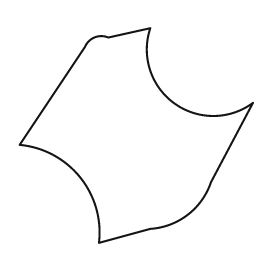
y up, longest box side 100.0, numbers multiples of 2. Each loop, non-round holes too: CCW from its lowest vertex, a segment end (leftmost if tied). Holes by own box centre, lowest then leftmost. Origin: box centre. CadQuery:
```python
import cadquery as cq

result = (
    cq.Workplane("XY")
    .moveTo(-16.0, -46.0)
    .lineTo(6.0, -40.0)
    .threePointArc((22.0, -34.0), (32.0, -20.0))
    .lineTo(50.0, 14.0)
    .threePointArc((16.0, 14.0), (6.0, 46.0))
    .lineTo(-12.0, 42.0)
    .threePointArc((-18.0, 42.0), (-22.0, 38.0))
    .lineTo(-50.0, -4.0)
    .threePointArc((-24.0, -18.0), (-16.0, -46.0))
    .close()
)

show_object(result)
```